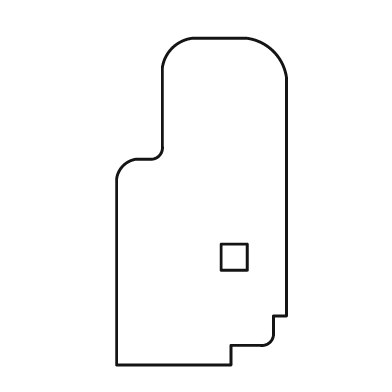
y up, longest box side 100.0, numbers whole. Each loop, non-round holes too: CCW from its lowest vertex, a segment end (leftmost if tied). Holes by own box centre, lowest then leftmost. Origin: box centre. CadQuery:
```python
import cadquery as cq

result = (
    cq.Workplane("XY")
    .moveTo(-26.0, -50.0)
    .lineTo(9.0, -50.0)
    .lineTo(9.0, -44.0)
    .lineTo(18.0, -44.0)
    .threePointArc((21.0, -43.0), (22.0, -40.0))
    .lineTo(22.0, -35.0)
    .lineTo(26.0, -35.0)
    .lineTo(26.0, 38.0)
    .threePointArc((22.0, 46.0), (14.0, 50.0))
    .lineTo(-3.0, 50.0)
    .threePointArc((-9.0, 47.0), (-12.0, 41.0))
    .lineTo(-12.0, 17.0)
    .threePointArc((-13.0, 14.0), (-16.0, 13.0))
    .lineTo(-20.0, 13.0)
    .threePointArc((-24.0, 11.0), (-26.0, 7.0))
    .close()
    .moveTo(6.0, -21.0)
    .lineTo(14.0, -21.0)
    .lineTo(14.0, -13.0)
    .lineTo(6.0, -13.0)
    .close()
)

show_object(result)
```